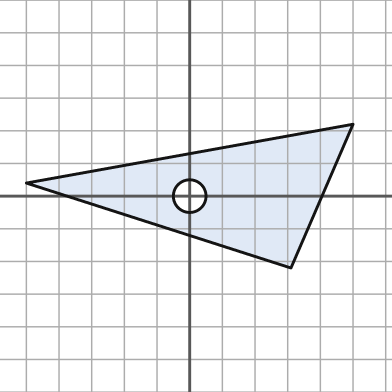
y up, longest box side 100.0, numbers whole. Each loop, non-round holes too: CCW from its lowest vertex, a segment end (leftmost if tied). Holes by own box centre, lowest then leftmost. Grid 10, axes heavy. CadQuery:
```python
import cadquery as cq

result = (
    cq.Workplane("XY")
    .moveTo(31.0, -22.0)
    .lineTo(50.0, 22.0)
    .lineTo(-50.0, 4.0)
    .close()
    .moveTo(0.0, 0.0)
    .circle(5.0)
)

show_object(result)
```